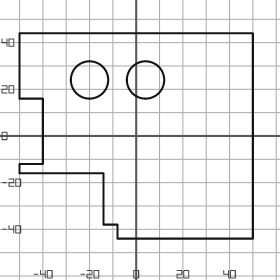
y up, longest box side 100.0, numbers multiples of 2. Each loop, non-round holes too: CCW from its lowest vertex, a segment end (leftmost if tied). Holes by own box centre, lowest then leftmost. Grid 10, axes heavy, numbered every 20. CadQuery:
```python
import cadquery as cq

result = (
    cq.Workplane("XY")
    .moveTo(-8.0, -44.0)
    .lineTo(50.0, -44.0)
    .lineTo(50.0, 44.0)
    .lineTo(-50.0, 44.0)
    .lineTo(-50.0, 16.0)
    .lineTo(-40.0, 16.0)
    .lineTo(-40.0, -12.0)
    .lineTo(-50.0, -12.0)
    .lineTo(-50.0, -16.0)
    .lineTo(-14.0, -16.0)
    .lineTo(-14.0, -38.0)
    .lineTo(-8.0, -38.0)
    .close()
    .moveTo(-20.0, 24.0)
    .circle(8.0)
    .moveTo(4.0, 24.0)
    .circle(8.0)
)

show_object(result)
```